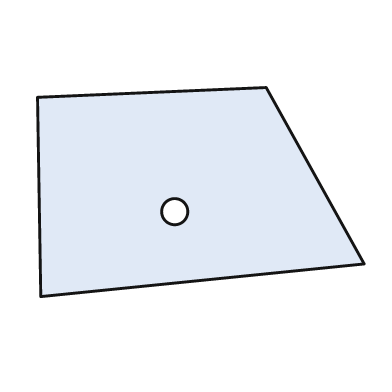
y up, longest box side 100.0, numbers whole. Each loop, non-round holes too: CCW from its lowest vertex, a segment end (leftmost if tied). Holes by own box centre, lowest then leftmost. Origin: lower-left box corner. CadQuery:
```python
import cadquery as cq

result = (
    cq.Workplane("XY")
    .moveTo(1.0, 0.0)
    .lineTo(100.0, 10.0)
    .lineTo(70.0, 64.0)
    .lineTo(0.0, 61.0)
    .close()
    .moveTo(42.0, 26.0)
    .circle(4.0)
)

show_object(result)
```